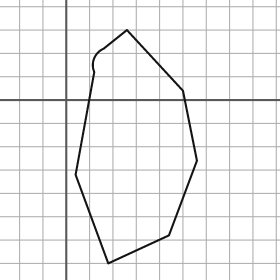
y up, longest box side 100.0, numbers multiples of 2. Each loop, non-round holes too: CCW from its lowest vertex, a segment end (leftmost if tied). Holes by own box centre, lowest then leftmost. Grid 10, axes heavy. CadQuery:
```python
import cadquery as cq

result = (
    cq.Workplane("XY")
    .moveTo(18.0, -70.0)
    .lineTo(44.0, -58.0)
    .lineTo(56.0, -26.0)
    .lineTo(50.0, 4.0)
    .lineTo(26.0, 30.0)
    .lineTo(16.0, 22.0)
    .threePointArc((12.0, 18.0), (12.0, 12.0))
    .lineTo(4.0, -32.0)
    .close()
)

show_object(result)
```